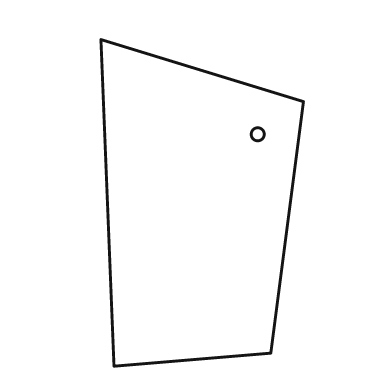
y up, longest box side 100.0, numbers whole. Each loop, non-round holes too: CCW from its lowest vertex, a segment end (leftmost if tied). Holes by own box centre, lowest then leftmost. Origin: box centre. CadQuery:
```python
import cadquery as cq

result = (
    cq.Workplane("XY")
    .moveTo(-27.0, -50.0)
    .lineTo(21.0, -46.0)
    .lineTo(31.0, 31.0)
    .lineTo(-31.0, 50.0)
    .close()
    .moveTo(17.0, 21.0)
    .circle(2.0)
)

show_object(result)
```